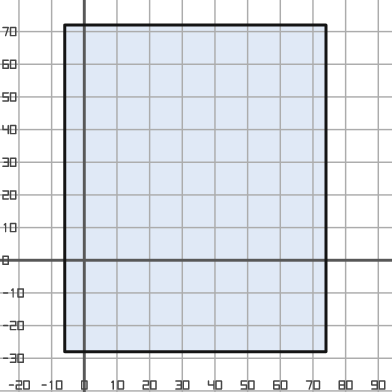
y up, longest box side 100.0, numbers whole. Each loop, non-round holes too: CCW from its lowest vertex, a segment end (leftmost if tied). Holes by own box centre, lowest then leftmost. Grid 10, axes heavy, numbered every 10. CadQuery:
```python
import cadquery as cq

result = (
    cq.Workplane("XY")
    .moveTo(-6.0, -28.0)
    .lineTo(74.0, -28.0)
    .lineTo(74.0, 72.0)
    .lineTo(-6.0, 72.0)
    .close()
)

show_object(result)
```